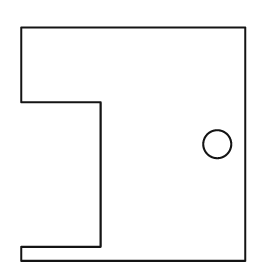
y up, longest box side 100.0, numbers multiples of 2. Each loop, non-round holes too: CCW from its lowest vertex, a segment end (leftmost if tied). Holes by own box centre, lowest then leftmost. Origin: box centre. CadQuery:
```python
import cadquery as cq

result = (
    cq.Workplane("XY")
    .moveTo(-48.0, -50.0)
    .lineTo(48.0, -50.0)
    .lineTo(48.0, 50.0)
    .lineTo(-48.0, 50.0)
    .lineTo(-48.0, 18.0)
    .lineTo(-14.0, 18.0)
    .lineTo(-14.0, -44.0)
    .lineTo(-48.0, -44.0)
    .close()
    .moveTo(36.0, 0.0)
    .circle(6.0)
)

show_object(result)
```